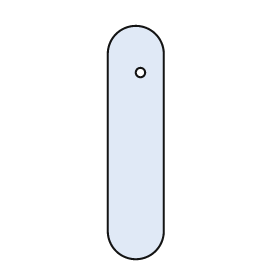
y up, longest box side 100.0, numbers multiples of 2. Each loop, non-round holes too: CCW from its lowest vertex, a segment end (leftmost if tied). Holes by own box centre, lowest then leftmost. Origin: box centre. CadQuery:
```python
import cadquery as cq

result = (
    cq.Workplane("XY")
    .moveTo(-12.0, -38.0)
    .threePointArc((0.0, -50.0), (12.0, -38.0))
    .lineTo(12.0, 38.0)
    .threePointArc((0.0, 50.0), (-12.0, 38.0))
    .close()
    .moveTo(2.0, 30.0)
    .circle(2.0)
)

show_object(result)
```